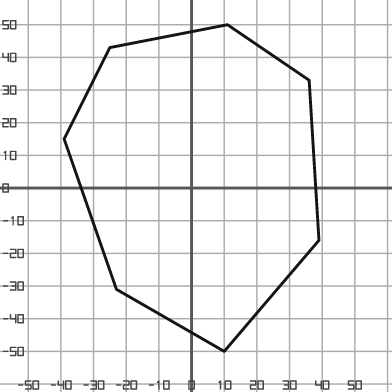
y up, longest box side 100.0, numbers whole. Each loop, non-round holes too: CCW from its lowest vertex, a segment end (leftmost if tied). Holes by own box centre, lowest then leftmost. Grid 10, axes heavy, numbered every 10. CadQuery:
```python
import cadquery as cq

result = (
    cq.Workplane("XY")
    .moveTo(10.0, -50.0)
    .lineTo(39.0, -16.0)
    .lineTo(36.0, 33.0)
    .lineTo(11.0, 50.0)
    .lineTo(-25.0, 43.0)
    .lineTo(-39.0, 15.0)
    .lineTo(-23.0, -31.0)
    .close()
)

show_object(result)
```